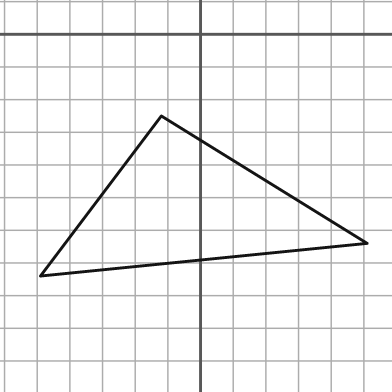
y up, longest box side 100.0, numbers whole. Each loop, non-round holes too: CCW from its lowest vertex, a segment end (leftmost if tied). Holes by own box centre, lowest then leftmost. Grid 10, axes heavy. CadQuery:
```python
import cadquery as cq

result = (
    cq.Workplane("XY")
    .moveTo(-49.0, -74.0)
    .lineTo(51.0, -64.0)
    .lineTo(-12.0, -25.0)
    .close()
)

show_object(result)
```